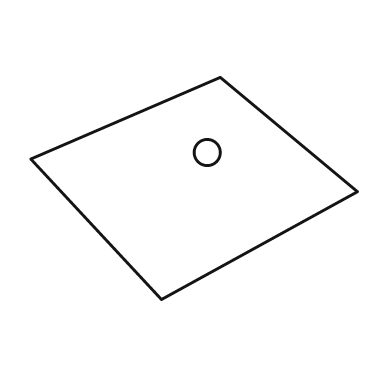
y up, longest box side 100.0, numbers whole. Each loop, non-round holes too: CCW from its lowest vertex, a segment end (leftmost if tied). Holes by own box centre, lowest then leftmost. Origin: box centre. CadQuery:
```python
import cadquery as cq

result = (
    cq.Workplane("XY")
    .moveTo(-10.0, -34.0)
    .lineTo(50.0, -1.0)
    .lineTo(8.0, 34.0)
    .lineTo(-50.0, 9.0)
    .close()
    .moveTo(4.0, 11.0)
    .circle(4.0)
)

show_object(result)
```